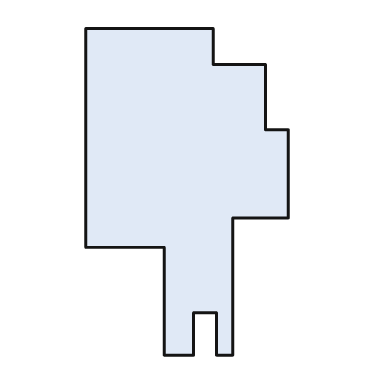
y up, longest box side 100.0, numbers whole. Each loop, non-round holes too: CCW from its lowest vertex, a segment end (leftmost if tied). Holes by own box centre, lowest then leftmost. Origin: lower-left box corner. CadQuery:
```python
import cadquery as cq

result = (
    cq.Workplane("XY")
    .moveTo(24.0, 0.0)
    .lineTo(33.0, 0.0)
    .lineTo(33.0, 13.0)
    .lineTo(40.0, 13.0)
    .lineTo(40.0, 0.0)
    .lineTo(45.0, 0.0)
    .lineTo(45.0, 42.0)
    .lineTo(62.0, 42.0)
    .lineTo(62.0, 69.0)
    .lineTo(55.0, 69.0)
    .lineTo(55.0, 89.0)
    .lineTo(39.0, 89.0)
    .lineTo(39.0, 100.0)
    .lineTo(0.0, 100.0)
    .lineTo(0.0, 33.0)
    .lineTo(24.0, 33.0)
    .close()
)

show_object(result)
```